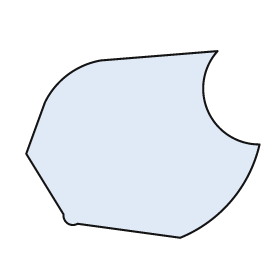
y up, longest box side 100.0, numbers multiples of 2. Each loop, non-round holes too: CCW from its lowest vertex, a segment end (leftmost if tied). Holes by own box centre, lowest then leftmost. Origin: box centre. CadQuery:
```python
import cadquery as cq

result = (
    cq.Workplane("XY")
    .moveTo(16.0, -40.0)
    .threePointArc((38.0, -24.0), (50.0, 0.0))
    .threePointArc((28.0, 14.0), (32.0, 40.0))
    .lineTo(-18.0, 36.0)
    .threePointArc((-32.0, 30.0), (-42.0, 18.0))
    .lineTo(-50.0, -4.0)
    .lineTo(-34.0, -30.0)
    .threePointArc((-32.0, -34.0), (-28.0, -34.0))
    .close()
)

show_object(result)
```